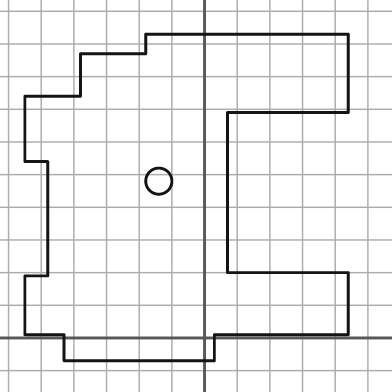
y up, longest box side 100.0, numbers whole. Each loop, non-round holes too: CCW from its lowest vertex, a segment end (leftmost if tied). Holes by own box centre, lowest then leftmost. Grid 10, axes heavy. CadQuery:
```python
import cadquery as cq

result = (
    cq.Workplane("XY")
    .moveTo(-43.0, -7.0)
    .lineTo(3.0, -7.0)
    .lineTo(3.0, 1.0)
    .lineTo(44.0, 1.0)
    .lineTo(44.0, 20.0)
    .lineTo(7.0, 20.0)
    .lineTo(7.0, 69.0)
    .lineTo(44.0, 69.0)
    .lineTo(44.0, 93.0)
    .lineTo(-18.0, 93.0)
    .lineTo(-18.0, 87.0)
    .lineTo(-38.0, 87.0)
    .lineTo(-38.0, 74.0)
    .lineTo(-55.0, 74.0)
    .lineTo(-55.0, 54.0)
    .lineTo(-48.0, 54.0)
    .lineTo(-48.0, 19.0)
    .lineTo(-55.0, 19.0)
    .lineTo(-55.0, 1.0)
    .lineTo(-43.0, 1.0)
    .close()
    .moveTo(-14.0, 48.0)
    .circle(4.0)
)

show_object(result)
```